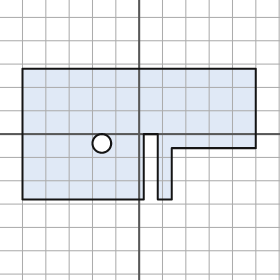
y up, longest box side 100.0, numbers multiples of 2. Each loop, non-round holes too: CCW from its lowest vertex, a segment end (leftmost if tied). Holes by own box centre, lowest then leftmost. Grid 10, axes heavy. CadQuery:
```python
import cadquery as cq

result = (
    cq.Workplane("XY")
    .moveTo(-50.0, -28.0)
    .lineTo(2.0, -28.0)
    .lineTo(2.0, 0.0)
    .lineTo(8.0, 0.0)
    .lineTo(8.0, -28.0)
    .lineTo(14.0, -28.0)
    .lineTo(14.0, -6.0)
    .lineTo(50.0, -6.0)
    .lineTo(50.0, 28.0)
    .lineTo(-50.0, 28.0)
    .close()
    .moveTo(-16.0, -4.0)
    .circle(4.0)
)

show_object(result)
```